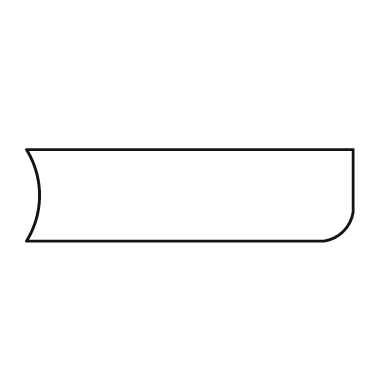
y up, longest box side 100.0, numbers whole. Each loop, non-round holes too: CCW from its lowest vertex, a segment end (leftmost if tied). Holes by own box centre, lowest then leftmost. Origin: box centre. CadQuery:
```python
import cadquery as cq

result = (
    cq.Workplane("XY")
    .moveTo(-50.0, -14.0)
    .lineTo(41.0, -14.0)
    .threePointArc((47.0, -11.0), (50.0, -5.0))
    .lineTo(50.0, 14.0)
    .lineTo(-50.0, 14.0)
    .threePointArc((-46.0, 0.0), (-50.0, -14.0))
    .close()
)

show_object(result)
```